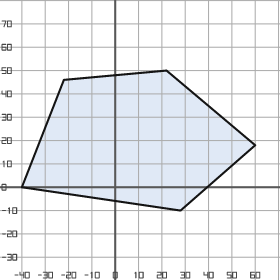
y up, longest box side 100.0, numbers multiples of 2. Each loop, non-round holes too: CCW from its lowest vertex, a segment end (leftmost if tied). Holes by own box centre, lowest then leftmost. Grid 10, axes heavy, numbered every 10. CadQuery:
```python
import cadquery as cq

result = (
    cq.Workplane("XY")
    .moveTo(28.0, -10.0)
    .lineTo(60.0, 18.0)
    .lineTo(22.0, 50.0)
    .lineTo(-22.0, 46.0)
    .lineTo(-40.0, 0.0)
    .close()
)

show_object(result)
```